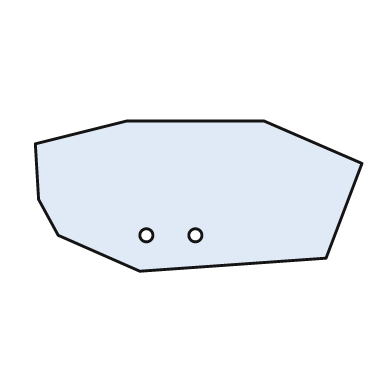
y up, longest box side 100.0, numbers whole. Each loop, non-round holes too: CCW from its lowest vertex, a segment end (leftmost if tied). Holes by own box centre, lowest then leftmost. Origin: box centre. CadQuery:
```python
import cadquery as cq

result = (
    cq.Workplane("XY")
    .moveTo(-18.0, -23.0)
    .lineTo(39.0, -19.0)
    .lineTo(50.0, 10.0)
    .lineTo(20.0, 23.0)
    .lineTo(-22.0, 23.0)
    .lineTo(-50.0, 16.0)
    .lineTo(-49.0, -1.0)
    .lineTo(-43.0, -12.0)
    .close()
    .moveTo(-16.0, -12.0)
    .circle(2.0)
    .moveTo(-1.0, -12.0)
    .circle(2.0)
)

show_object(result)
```